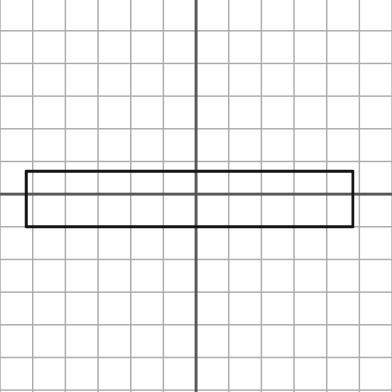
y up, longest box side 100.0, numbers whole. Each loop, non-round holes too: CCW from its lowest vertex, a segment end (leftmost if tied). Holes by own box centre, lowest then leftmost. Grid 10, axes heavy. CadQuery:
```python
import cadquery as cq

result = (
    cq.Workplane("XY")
    .moveTo(-52.0, -10.0)
    .lineTo(48.0, -10.0)
    .lineTo(48.0, 7.0)
    .lineTo(-52.0, 7.0)
    .close()
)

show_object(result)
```